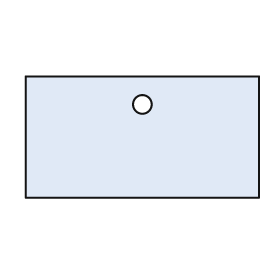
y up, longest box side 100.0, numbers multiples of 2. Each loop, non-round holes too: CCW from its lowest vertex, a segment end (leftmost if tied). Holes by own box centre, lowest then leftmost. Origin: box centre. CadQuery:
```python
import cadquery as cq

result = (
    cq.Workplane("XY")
    .moveTo(-50.0, -26.0)
    .lineTo(50.0, -26.0)
    .lineTo(50.0, 26.0)
    .lineTo(-50.0, 26.0)
    .close()
    .moveTo(0.0, 14.0)
    .circle(4.0)
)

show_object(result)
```